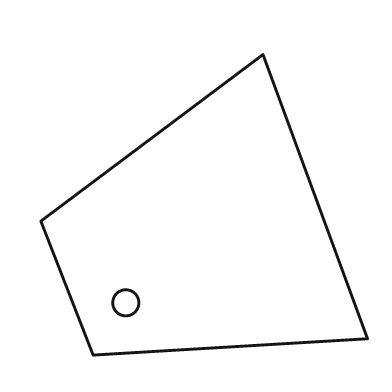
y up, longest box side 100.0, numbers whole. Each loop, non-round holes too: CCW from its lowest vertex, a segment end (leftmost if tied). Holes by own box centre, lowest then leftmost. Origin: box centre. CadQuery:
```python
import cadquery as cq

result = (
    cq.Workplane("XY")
    .moveTo(-34.0, -46.0)
    .lineTo(50.0, -41.0)
    .lineTo(18.0, 46.0)
    .lineTo(-50.0, -5.0)
    .close()
    .moveTo(-24.0, -30.0)
    .circle(4.0)
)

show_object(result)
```